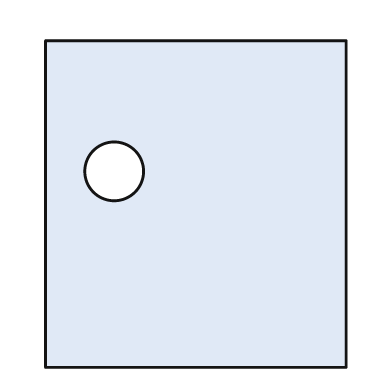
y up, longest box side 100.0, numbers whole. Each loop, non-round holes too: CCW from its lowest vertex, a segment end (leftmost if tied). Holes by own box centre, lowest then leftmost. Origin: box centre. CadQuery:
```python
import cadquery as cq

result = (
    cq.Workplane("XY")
    .moveTo(-46.0, -50.0)
    .lineTo(46.0, -50.0)
    .lineTo(46.0, 50.0)
    .lineTo(-46.0, 50.0)
    .close()
    .moveTo(-25.0, 10.0)
    .circle(9.0)
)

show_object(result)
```